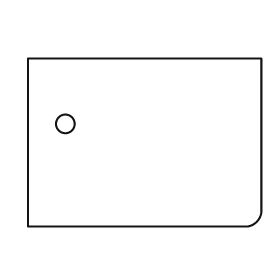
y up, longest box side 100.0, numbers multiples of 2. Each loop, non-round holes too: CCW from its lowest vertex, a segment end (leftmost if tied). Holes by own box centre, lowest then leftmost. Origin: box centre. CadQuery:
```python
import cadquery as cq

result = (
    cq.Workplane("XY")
    .moveTo(-50.0, -36.0)
    .lineTo(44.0, -36.0)
    .threePointArc((48.0, -34.0), (50.0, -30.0))
    .lineTo(50.0, 36.0)
    .lineTo(-50.0, 36.0)
    .close()
    .moveTo(-34.0, 8.0)
    .circle(4.0)
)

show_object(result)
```